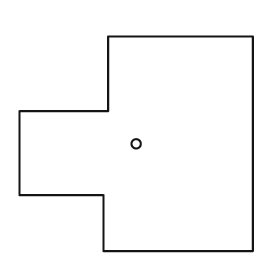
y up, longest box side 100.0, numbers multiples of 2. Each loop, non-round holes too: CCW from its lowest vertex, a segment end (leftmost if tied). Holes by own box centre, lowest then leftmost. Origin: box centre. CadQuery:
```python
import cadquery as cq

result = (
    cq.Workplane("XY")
    .moveTo(-14.0, -46.0)
    .lineTo(50.0, -46.0)
    .lineTo(50.0, 46.0)
    .lineTo(-12.0, 46.0)
    .lineTo(-12.0, 14.0)
    .lineTo(-50.0, 14.0)
    .lineTo(-50.0, -22.0)
    .lineTo(-14.0, -22.0)
    .close()
    .moveTo(0.0, 0.0)
    .circle(2.0)
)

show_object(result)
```